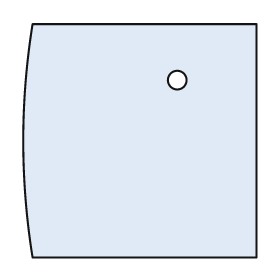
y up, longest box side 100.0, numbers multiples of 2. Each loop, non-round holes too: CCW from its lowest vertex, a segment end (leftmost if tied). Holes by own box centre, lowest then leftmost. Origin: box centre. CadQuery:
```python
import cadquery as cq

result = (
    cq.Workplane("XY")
    .moveTo(-46.0, -50.0)
    .lineTo(50.0, -50.0)
    .lineTo(50.0, 50.0)
    .lineTo(-46.0, 50.0)
    .threePointArc((-50.0, 0.0), (-46.0, -50.0))
    .close()
    .moveTo(16.0, 26.0)
    .circle(4.0)
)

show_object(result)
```